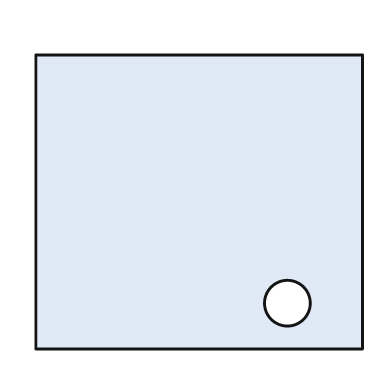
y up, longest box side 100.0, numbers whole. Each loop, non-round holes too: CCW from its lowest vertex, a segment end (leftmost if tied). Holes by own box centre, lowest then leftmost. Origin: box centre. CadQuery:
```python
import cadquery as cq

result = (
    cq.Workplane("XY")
    .moveTo(-50.0, -45.0)
    .lineTo(50.0, -45.0)
    .lineTo(50.0, 45.0)
    .lineTo(-50.0, 45.0)
    .close()
    .moveTo(27.0, -31.0)
    .circle(7.0)
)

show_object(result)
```